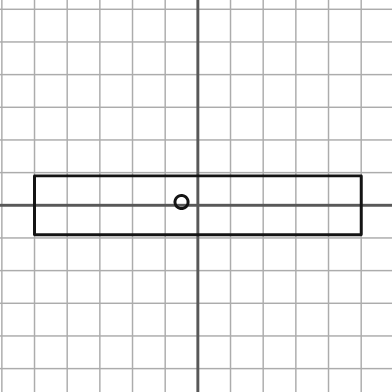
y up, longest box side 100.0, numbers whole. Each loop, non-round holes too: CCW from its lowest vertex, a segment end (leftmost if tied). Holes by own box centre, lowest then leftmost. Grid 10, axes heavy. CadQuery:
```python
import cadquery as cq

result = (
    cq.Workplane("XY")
    .moveTo(-50.0, -9.0)
    .lineTo(50.0, -9.0)
    .lineTo(50.0, 9.0)
    .lineTo(-50.0, 9.0)
    .close()
    .moveTo(-5.0, 1.0)
    .circle(2.0)
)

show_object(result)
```